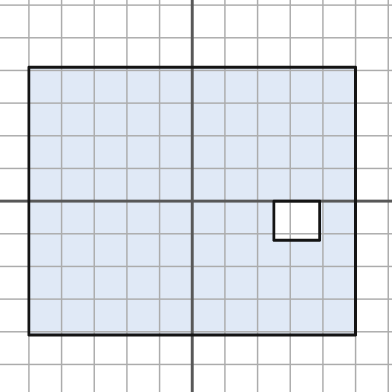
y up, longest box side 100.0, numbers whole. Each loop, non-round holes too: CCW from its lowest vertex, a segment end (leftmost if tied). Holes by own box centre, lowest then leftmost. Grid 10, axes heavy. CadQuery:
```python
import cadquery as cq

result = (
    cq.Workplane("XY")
    .moveTo(-50.0, -41.0)
    .lineTo(50.0, -41.0)
    .lineTo(50.0, 41.0)
    .lineTo(-50.0, 41.0)
    .close()
    .moveTo(25.0, -12.0)
    .lineTo(39.0, -12.0)
    .lineTo(39.0, 0.0)
    .lineTo(25.0, 0.0)
    .close()
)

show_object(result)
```